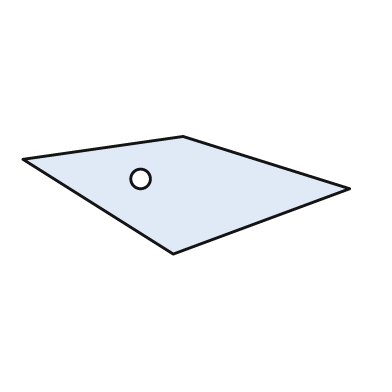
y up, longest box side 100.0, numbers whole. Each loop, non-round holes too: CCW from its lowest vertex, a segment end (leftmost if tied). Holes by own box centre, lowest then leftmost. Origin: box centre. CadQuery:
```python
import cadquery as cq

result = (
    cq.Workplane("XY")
    .moveTo(-4.0, -18.0)
    .lineTo(50.0, 2.0)
    .lineTo(-1.0, 18.0)
    .lineTo(-50.0, 11.0)
    .close()
    .moveTo(-14.0, 5.0)
    .circle(3.0)
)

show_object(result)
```